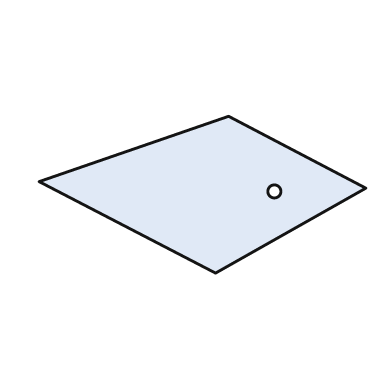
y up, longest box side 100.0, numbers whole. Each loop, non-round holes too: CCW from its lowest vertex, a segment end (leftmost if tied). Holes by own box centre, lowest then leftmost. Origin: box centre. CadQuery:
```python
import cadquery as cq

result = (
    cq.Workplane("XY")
    .moveTo(4.0, -24.0)
    .lineTo(50.0, 2.0)
    .lineTo(8.0, 24.0)
    .lineTo(-50.0, 4.0)
    .close()
    .moveTo(22.0, 1.0)
    .circle(2.0)
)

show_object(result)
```